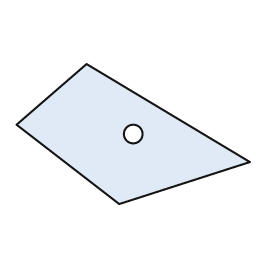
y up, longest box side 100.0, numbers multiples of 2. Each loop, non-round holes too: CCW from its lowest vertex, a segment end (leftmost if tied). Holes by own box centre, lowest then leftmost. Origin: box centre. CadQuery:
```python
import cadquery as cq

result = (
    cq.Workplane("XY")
    .moveTo(-6.0, -30.0)
    .lineTo(50.0, -12.0)
    .lineTo(-20.0, 30.0)
    .lineTo(-50.0, 4.0)
    .close()
    .moveTo(0.0, 0.0)
    .circle(4.0)
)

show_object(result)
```